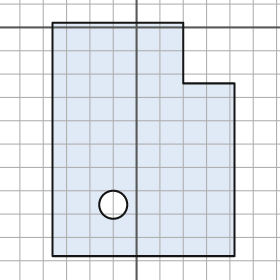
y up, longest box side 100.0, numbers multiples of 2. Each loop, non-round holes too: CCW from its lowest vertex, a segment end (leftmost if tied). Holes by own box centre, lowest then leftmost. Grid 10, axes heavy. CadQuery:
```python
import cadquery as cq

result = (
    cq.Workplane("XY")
    .moveTo(-36.0, -98.0)
    .lineTo(42.0, -98.0)
    .lineTo(42.0, -24.0)
    .lineTo(20.0, -24.0)
    .lineTo(20.0, 2.0)
    .lineTo(-36.0, 2.0)
    .close()
    .moveTo(-10.0, -76.0)
    .circle(6.0)
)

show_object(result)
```